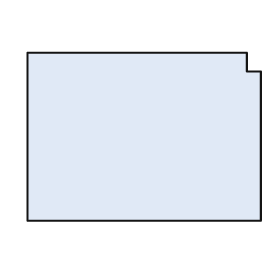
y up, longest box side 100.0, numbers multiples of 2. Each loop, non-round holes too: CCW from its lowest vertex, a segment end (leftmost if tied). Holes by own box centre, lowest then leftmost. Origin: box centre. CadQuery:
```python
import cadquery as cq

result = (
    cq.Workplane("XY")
    .moveTo(-50.0, -36.0)
    .lineTo(50.0, -36.0)
    .lineTo(50.0, 28.0)
    .lineTo(44.0, 28.0)
    .lineTo(44.0, 36.0)
    .lineTo(-50.0, 36.0)
    .close()
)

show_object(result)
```